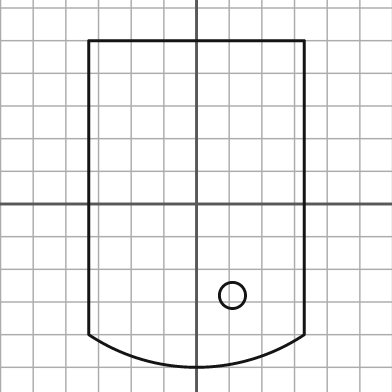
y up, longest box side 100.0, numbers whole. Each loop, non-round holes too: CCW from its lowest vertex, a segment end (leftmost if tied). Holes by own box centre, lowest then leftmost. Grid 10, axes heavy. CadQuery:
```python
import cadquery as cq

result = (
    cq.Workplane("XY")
    .moveTo(-33.0, -40.0)
    .threePointArc((0.0, -50.0), (33.0, -40.0))
    .lineTo(33.0, 50.0)
    .lineTo(-33.0, 50.0)
    .close()
    .moveTo(11.0, -28.0)
    .circle(4.0)
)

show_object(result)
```